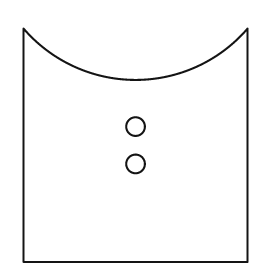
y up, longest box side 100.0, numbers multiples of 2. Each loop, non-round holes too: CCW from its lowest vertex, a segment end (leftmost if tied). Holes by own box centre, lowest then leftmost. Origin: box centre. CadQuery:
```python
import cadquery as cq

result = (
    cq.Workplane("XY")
    .moveTo(-48.0, -50.0)
    .lineTo(48.0, -50.0)
    .lineTo(48.0, 50.0)
    .threePointArc((0.0, 28.0), (-48.0, 50.0))
    .close()
    .moveTo(0.0, -8.0)
    .circle(4.0)
    .moveTo(0.0, 8.0)
    .circle(4.0)
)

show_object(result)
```